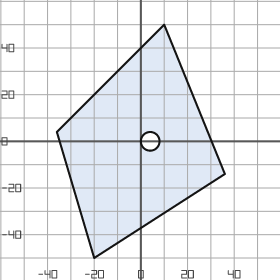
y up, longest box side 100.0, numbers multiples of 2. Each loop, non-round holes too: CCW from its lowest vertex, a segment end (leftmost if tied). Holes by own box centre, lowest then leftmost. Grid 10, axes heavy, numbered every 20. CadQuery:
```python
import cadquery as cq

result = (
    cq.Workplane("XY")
    .moveTo(-20.0, -50.0)
    .lineTo(36.0, -14.0)
    .lineTo(10.0, 50.0)
    .lineTo(-36.0, 4.0)
    .close()
    .moveTo(4.0, 0.0)
    .circle(4.0)
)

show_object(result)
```